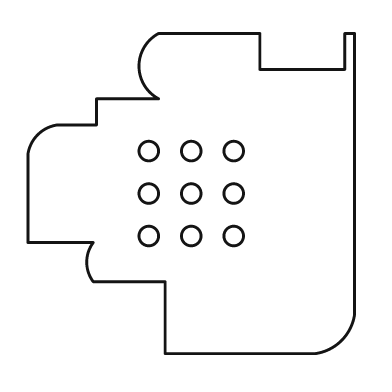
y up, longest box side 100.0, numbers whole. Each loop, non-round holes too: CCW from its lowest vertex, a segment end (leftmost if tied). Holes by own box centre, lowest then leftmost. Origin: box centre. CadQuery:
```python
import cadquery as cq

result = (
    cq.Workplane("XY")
    .moveTo(-8.0, -49.0)
    .lineTo(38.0, -49.0)
    .threePointArc((46.0, -45.0), (50.0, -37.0))
    .lineTo(50.0, 49.0)
    .lineTo(47.0, 49.0)
    .lineTo(47.0, 38.0)
    .lineTo(21.0, 38.0)
    .lineTo(21.0, 49.0)
    .lineTo(-10.0, 49.0)
    .threePointArc((-16.0, 39.0), (-10.0, 29.0))
    .lineTo(-29.0, 29.0)
    .lineTo(-29.0, 21.0)
    .lineTo(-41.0, 21.0)
    .threePointArc((-47.0, 18.0), (-50.0, 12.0))
    .lineTo(-50.0, -15.0)
    .lineTo(-30.0, -15.0)
    .threePointArc((-32.0, -21.0), (-30.0, -27.0))
    .lineTo(-8.0, -27.0)
    .close()
    .moveTo(-13.0, -13.0)
    .circle(3.0)
    .moveTo(0.0, -13.0)
    .circle(3.0)
    .moveTo(13.0, -13.0)
    .circle(3.0)
    .moveTo(-13.0, 0.0)
    .circle(3.0)
    .moveTo(0.0, 0.0)
    .circle(3.0)
    .moveTo(13.0, 0.0)
    .circle(3.0)
    .moveTo(-13.0, 13.0)
    .circle(3.0)
    .moveTo(0.0, 13.0)
    .circle(3.0)
    .moveTo(13.0, 13.0)
    .circle(3.0)
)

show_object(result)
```